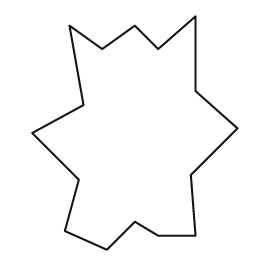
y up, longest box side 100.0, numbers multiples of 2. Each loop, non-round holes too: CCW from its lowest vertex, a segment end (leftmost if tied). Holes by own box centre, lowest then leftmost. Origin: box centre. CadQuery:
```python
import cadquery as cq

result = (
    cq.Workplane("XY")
    .moveTo(-12.0, -50.0)
    .lineTo(0.0, -38.0)
    .lineTo(10.0, -44.0)
    .lineTo(26.0, -44.0)
    .lineTo(24.0, -18.0)
    .lineTo(44.0, 2.0)
    .lineTo(26.0, 18.0)
    .lineTo(26.0, 50.0)
    .lineTo(10.0, 36.0)
    .lineTo(0.0, 46.0)
    .lineTo(-14.0, 36.0)
    .lineTo(-28.0, 46.0)
    .lineTo(-22.0, 12.0)
    .lineTo(-44.0, 0.0)
    .lineTo(-24.0, -20.0)
    .lineTo(-30.0, -42.0)
    .close()
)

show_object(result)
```